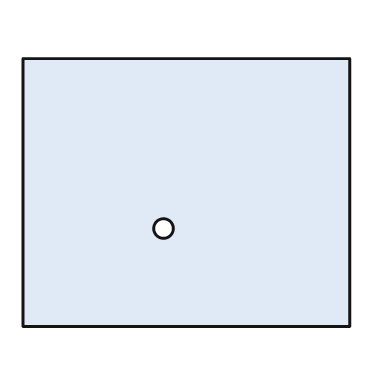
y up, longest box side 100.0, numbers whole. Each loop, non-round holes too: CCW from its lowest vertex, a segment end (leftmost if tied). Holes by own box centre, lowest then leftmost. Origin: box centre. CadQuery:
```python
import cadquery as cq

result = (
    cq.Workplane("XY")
    .moveTo(-50.0, -41.0)
    .lineTo(50.0, -41.0)
    .lineTo(50.0, 41.0)
    .lineTo(-50.0, 41.0)
    .close()
    .moveTo(-7.0, -11.0)
    .circle(3.0)
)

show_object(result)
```